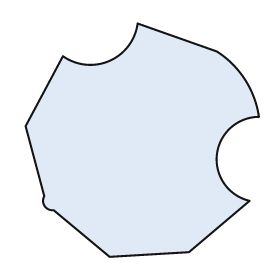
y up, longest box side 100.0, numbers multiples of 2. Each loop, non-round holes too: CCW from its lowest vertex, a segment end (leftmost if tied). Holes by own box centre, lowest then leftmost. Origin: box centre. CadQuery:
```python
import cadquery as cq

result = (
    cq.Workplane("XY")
    .moveTo(-14.0, -50.0)
    .lineTo(20.0, -48.0)
    .lineTo(46.0, -26.0)
    .threePointArc((32.0, -6.0), (50.0, 10.0))
    .threePointArc((44.0, 26.0), (32.0, 38.0))
    .lineTo(-2.0, 50.0)
    .threePointArc((-14.0, 34.0), (-34.0, 36.0))
    .lineTo(-50.0, 6.0)
    .lineTo(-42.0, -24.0)
    .threePointArc((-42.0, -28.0), (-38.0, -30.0))
    .close()
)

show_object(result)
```